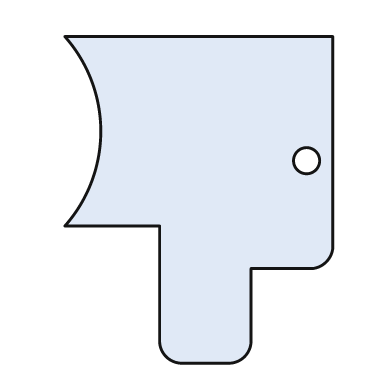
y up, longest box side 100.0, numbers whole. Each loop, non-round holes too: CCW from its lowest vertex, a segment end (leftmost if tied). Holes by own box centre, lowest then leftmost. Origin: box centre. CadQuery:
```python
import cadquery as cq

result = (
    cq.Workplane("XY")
    .moveTo(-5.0, -50.0)
    .lineTo(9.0, -50.0)
    .threePointArc((14.0, -48.0), (16.0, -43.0))
    .lineTo(16.0, -21.0)
    .lineTo(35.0, -21.0)
    .threePointArc((39.0, -19.0), (41.0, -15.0))
    .lineTo(41.0, 50.0)
    .lineTo(-41.0, 50.0)
    .threePointArc((-30.0, 21.0), (-41.0, -8.0))
    .lineTo(-12.0, -8.0)
    .lineTo(-12.0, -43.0)
    .threePointArc((-10.0, -48.0), (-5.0, -50.0))
    .close()
    .moveTo(33.0, 12.0)
    .circle(4.0)
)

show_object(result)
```